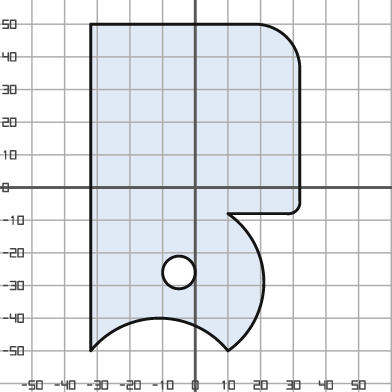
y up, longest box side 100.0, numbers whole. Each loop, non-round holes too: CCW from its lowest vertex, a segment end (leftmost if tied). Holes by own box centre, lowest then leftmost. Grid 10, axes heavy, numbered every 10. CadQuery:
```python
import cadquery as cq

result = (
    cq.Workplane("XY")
    .moveTo(-32.0, -50.0)
    .threePointArc((-11.0, -40.0), (10.0, -50.0))
    .threePointArc((21.0, -29.0), (10.0, -8.0))
    .lineTo(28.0, -8.0)
    .threePointArc((31.0, -7.0), (32.0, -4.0))
    .lineTo(32.0, 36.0)
    .threePointArc((28.0, 46.0), (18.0, 50.0))
    .lineTo(-32.0, 50.0)
    .close()
    .moveTo(-5.0, -26.0)
    .circle(5.0)
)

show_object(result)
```